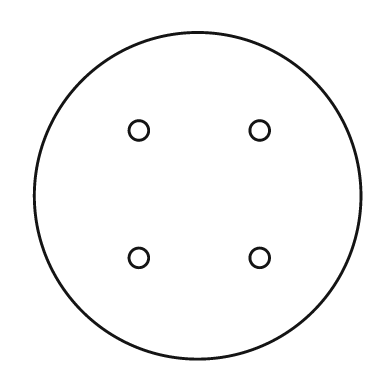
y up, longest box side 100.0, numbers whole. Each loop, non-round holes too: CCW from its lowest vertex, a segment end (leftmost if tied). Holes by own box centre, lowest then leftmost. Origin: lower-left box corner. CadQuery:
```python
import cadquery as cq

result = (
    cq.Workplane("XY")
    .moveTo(50.0, 50.0)
    .circle(50.0)
    .moveTo(32.0, 31.0)
    .circle(3.0)
    .moveTo(69.0, 31.0)
    .circle(3.0)
    .moveTo(32.0, 70.0)
    .circle(3.0)
    .moveTo(69.0, 70.0)
    .circle(3.0)
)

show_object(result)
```